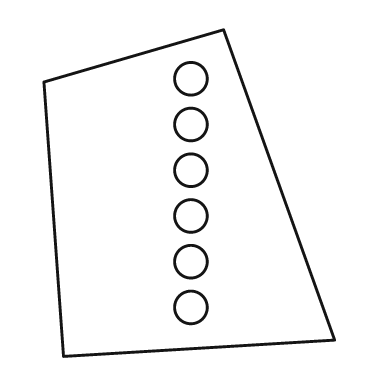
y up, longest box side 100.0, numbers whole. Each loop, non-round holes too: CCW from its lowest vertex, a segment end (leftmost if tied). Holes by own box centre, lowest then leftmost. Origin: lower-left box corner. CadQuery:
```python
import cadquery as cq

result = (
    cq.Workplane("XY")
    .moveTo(6.0, 0.0)
    .lineTo(89.0, 5.0)
    .lineTo(55.0, 100.0)
    .lineTo(0.0, 84.0)
    .close()
    .moveTo(45.0, 15.0)
    .circle(5.0)
    .moveTo(45.0, 29.0)
    .circle(5.0)
    .moveTo(45.0, 43.0)
    .circle(5.0)
    .moveTo(45.0, 57.0)
    .circle(5.0)
    .moveTo(45.0, 71.0)
    .circle(5.0)
    .moveTo(45.0, 85.0)
    .circle(5.0)
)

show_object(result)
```